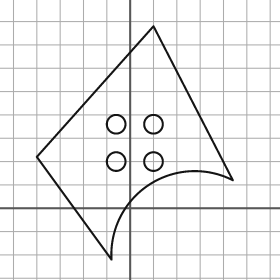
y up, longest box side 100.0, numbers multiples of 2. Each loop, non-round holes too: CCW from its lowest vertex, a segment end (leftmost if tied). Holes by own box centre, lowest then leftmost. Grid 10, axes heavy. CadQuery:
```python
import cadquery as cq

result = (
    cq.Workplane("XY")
    .moveTo(-8.0, -22.0)
    .threePointArc((8.0, 10.0), (44.0, 12.0))
    .lineTo(10.0, 78.0)
    .lineTo(-40.0, 22.0)
    .close()
    .moveTo(-6.0, 20.0)
    .circle(4.0)
    .moveTo(10.0, 20.0)
    .circle(4.0)
    .moveTo(-6.0, 36.0)
    .circle(4.0)
    .moveTo(10.0, 36.0)
    .circle(4.0)
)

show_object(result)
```